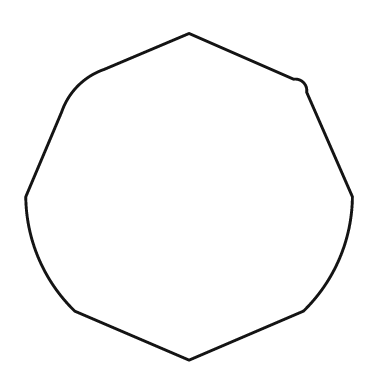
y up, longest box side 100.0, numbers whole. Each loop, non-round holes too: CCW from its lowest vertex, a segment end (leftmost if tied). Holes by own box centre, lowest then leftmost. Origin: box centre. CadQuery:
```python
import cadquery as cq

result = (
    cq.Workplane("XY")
    .moveTo(0.0, -50.0)
    .lineTo(35.0, -35.0)
    .threePointArc((46.0, -19.0), (50.0, 0.0))
    .lineTo(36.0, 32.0)
    .threePointArc((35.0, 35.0), (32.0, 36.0))
    .lineTo(0.0, 50.0)
    .lineTo(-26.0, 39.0)
    .threePointArc((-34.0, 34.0), (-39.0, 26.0))
    .lineTo(-50.0, 0.0)
    .threePointArc((-46.0, -19.0), (-35.0, -35.0))
    .close()
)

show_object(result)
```